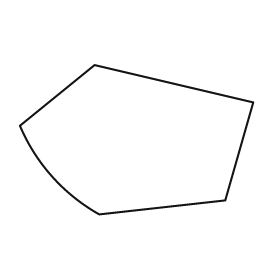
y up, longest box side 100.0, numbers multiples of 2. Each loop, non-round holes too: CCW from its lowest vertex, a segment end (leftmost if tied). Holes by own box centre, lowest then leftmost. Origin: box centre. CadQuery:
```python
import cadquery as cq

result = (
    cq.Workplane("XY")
    .moveTo(-16.0, -32.0)
    .lineTo(38.0, -26.0)
    .lineTo(50.0, 16.0)
    .lineTo(-18.0, 32.0)
    .lineTo(-50.0, 6.0)
    .threePointArc((-36.0, -16.0), (-16.0, -32.0))
    .close()
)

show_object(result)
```